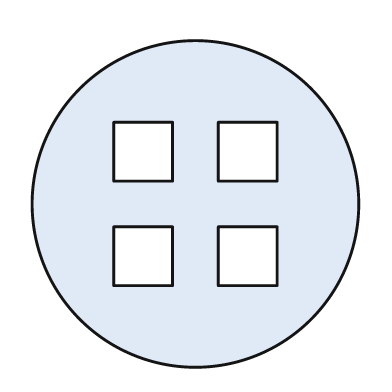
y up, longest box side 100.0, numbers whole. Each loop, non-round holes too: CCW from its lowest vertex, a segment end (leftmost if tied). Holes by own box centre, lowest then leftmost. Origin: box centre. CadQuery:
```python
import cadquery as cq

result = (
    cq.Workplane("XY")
    .moveTo(0.0, 0.0)
    .circle(50.0)
    .moveTo(-25.0, -25.0)
    .lineTo(-7.0, -25.0)
    .lineTo(-7.0, -7.0)
    .lineTo(-25.0, -7.0)
    .close()
    .moveTo(7.0, -25.0)
    .lineTo(25.0, -25.0)
    .lineTo(25.0, -7.0)
    .lineTo(7.0, -7.0)
    .close()
    .moveTo(-25.0, 7.0)
    .lineTo(-7.0, 7.0)
    .lineTo(-7.0, 25.0)
    .lineTo(-25.0, 25.0)
    .close()
    .moveTo(7.0, 7.0)
    .lineTo(25.0, 7.0)
    .lineTo(25.0, 25.0)
    .lineTo(7.0, 25.0)
    .close()
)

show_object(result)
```